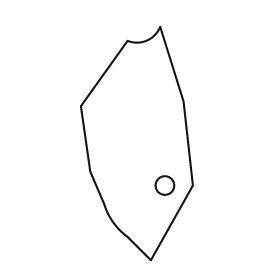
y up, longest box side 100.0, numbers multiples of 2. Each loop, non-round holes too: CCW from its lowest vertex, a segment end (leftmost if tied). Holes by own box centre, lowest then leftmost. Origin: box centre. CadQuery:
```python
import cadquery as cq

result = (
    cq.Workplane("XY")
    .moveTo(6.0, -50.0)
    .lineTo(24.0, -18.0)
    .lineTo(20.0, 18.0)
    .lineTo(10.0, 50.0)
    .threePointArc((4.0, 44.0), (-4.0, 44.0))
    .lineTo(-24.0, 16.0)
    .lineTo(-20.0, -12.0)
    .lineTo(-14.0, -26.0)
    .threePointArc((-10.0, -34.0), (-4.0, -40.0))
    .close()
    .moveTo(12.0, -18.0)
    .circle(4.0)
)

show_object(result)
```